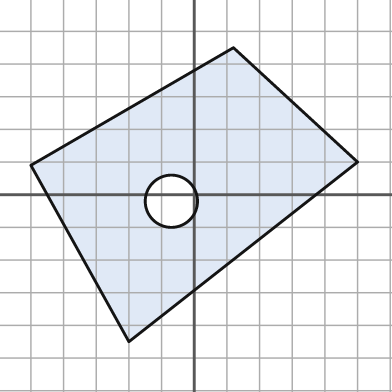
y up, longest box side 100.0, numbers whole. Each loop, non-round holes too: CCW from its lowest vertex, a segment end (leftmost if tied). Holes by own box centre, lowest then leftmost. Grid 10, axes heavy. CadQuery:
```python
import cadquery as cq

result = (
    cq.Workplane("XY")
    .moveTo(-20.0, -45.0)
    .lineTo(50.0, 10.0)
    .lineTo(12.0, 45.0)
    .lineTo(-50.0, 9.0)
    .close()
    .moveTo(-7.0, -2.0)
    .circle(8.0)
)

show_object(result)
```